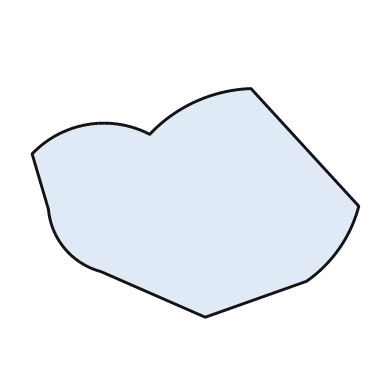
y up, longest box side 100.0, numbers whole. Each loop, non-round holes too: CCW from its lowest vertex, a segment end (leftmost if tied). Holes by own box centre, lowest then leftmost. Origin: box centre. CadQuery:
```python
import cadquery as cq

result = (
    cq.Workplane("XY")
    .moveTo(3.0, -35.0)
    .lineTo(34.0, -24.0)
    .threePointArc((44.0, -14.0), (50.0, -1.0))
    .lineTo(17.0, 35.0)
    .threePointArc((0.0, 31.0), (-14.0, 21.0))
    .threePointArc((-33.0, 24.0), (-50.0, 15.0))
    .lineTo(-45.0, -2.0)
    .threePointArc((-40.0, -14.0), (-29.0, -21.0))
    .close()
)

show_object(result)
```